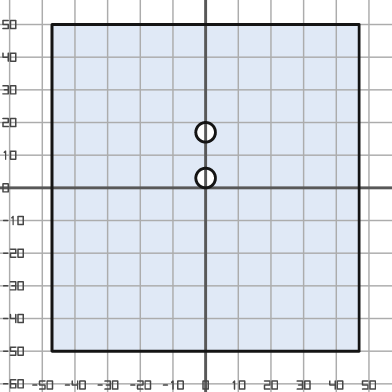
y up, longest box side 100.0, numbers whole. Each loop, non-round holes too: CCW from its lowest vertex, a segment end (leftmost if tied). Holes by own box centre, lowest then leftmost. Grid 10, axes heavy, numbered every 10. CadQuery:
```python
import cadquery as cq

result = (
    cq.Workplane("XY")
    .moveTo(-47.0, -50.0)
    .lineTo(47.0, -50.0)
    .lineTo(47.0, 50.0)
    .lineTo(-47.0, 50.0)
    .close()
    .moveTo(0.0, 3.0)
    .circle(3.0)
    .moveTo(0.0, 17.0)
    .circle(3.0)
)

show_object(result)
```